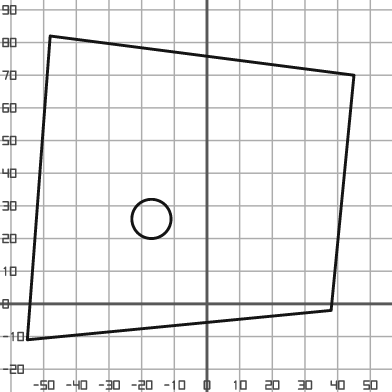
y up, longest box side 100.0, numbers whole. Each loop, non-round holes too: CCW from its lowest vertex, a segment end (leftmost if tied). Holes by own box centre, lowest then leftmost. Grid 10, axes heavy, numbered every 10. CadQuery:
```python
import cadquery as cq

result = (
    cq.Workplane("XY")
    .moveTo(-55.0, -11.0)
    .lineTo(38.0, -2.0)
    .lineTo(45.0, 70.0)
    .lineTo(-48.0, 82.0)
    .close()
    .moveTo(-17.0, 26.0)
    .circle(6.0)
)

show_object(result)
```